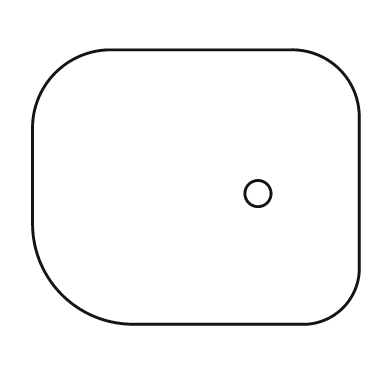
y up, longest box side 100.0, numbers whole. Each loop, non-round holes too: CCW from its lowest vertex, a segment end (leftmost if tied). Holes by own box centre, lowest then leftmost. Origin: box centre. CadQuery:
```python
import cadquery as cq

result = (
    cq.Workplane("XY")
    .moveTo(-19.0, -42.0)
    .lineTo(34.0, -42.0)
    .threePointArc((45.0, -37.0), (50.0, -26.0))
    .lineTo(50.0, 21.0)
    .threePointArc((44.0, 36.0), (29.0, 42.0))
    .lineTo(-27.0, 42.0)
    .threePointArc((-43.0, 35.0), (-50.0, 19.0))
    .lineTo(-50.0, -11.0)
    .threePointArc((-41.0, -33.0), (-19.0, -42.0))
    .close()
    .moveTo(19.0, -2.0)
    .circle(4.0)
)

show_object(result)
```